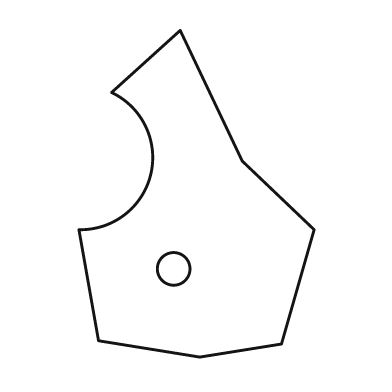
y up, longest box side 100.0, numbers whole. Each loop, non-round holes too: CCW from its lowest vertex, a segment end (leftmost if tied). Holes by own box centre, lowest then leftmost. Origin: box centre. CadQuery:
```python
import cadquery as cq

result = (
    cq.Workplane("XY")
    .moveTo(1.0, -50.0)
    .lineTo(26.0, -46.0)
    .lineTo(36.0, -11.0)
    .lineTo(14.0, 10.0)
    .lineTo(-5.0, 50.0)
    .lineTo(-26.0, 31.0)
    .threePointArc((-14.0, 6.0), (-36.0, -11.0))
    .lineTo(-30.0, -45.0)
    .close()
    .moveTo(-7.0, -23.0)
    .circle(5.0)
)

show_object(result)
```